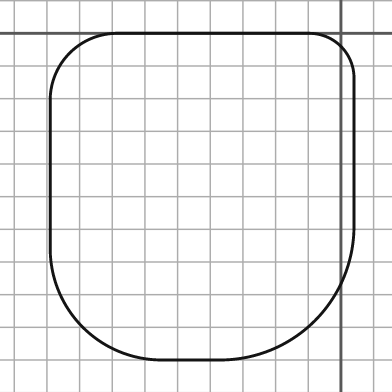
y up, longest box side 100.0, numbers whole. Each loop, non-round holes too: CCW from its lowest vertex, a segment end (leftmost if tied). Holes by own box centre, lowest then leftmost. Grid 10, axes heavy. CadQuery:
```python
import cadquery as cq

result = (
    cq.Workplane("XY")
    .moveTo(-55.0, -100.0)
    .lineTo(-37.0, -100.0)
    .threePointArc((-8.0, -88.0), (4.0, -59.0))
    .lineTo(4.0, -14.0)
    .threePointArc((0.0, -4.0), (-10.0, 0.0))
    .lineTo(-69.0, 0.0)
    .threePointArc((-83.0, -6.0), (-89.0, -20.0))
    .lineTo(-89.0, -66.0)
    .threePointArc((-79.0, -90.0), (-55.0, -100.0))
    .close()
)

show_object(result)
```